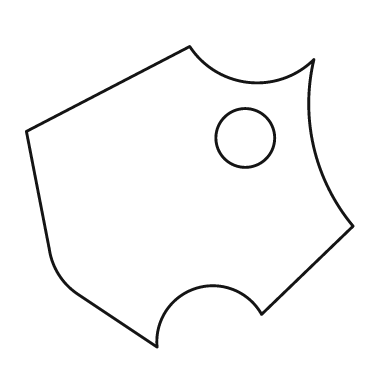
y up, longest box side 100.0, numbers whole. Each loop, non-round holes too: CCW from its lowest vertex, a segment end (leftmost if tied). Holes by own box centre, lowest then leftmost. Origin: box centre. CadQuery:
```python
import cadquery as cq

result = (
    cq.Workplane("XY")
    .moveTo(-10.0, -46.0)
    .threePointArc((2.0, -28.0), (22.0, -36.0))
    .lineTo(50.0, -9.0)
    .threePointArc((38.0, 15.0), (38.0, 42.0))
    .threePointArc((18.0, 35.0), (0.0, 46.0))
    .lineTo(-50.0, 20.0)
    .lineTo(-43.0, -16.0)
    .threePointArc((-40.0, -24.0), (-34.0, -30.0))
    .close()
    .moveTo(17.0, 18.0)
    .circle(9.0)
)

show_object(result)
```